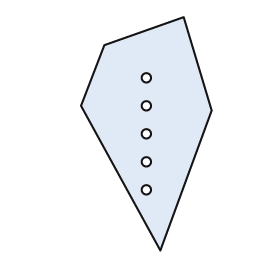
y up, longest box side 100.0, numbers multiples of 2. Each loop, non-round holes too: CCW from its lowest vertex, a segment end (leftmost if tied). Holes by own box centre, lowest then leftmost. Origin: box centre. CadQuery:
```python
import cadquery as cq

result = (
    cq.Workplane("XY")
    .moveTo(6.0, -50.0)
    .lineTo(28.0, 10.0)
    .lineTo(16.0, 50.0)
    .lineTo(-18.0, 38.0)
    .lineTo(-28.0, 12.0)
    .close()
    .moveTo(0.0, -24.0)
    .circle(2.0)
    .moveTo(0.0, -12.0)
    .circle(2.0)
    .moveTo(0.0, 0.0)
    .circle(2.0)
    .moveTo(0.0, 12.0)
    .circle(2.0)
    .moveTo(0.0, 24.0)
    .circle(2.0)
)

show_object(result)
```